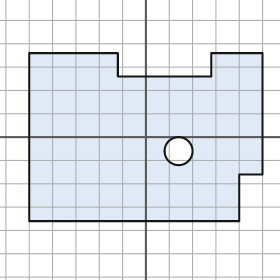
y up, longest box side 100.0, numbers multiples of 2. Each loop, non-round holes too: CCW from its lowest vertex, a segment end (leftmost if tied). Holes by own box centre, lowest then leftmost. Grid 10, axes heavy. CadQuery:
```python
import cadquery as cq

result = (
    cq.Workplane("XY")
    .moveTo(-50.0, -36.0)
    .lineTo(40.0, -36.0)
    .lineTo(40.0, -16.0)
    .lineTo(50.0, -16.0)
    .lineTo(50.0, 36.0)
    .lineTo(28.0, 36.0)
    .lineTo(28.0, 26.0)
    .lineTo(-12.0, 26.0)
    .lineTo(-12.0, 36.0)
    .lineTo(-50.0, 36.0)
    .close()
    .moveTo(14.0, -6.0)
    .circle(6.0)
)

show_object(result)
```